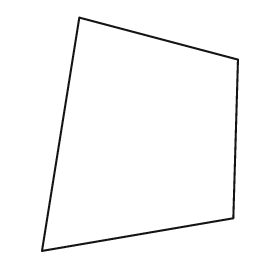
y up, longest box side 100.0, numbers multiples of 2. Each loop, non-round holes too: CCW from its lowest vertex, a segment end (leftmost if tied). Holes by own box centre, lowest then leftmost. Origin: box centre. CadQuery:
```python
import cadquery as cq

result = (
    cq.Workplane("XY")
    .moveTo(-42.0, -50.0)
    .lineTo(40.0, -36.0)
    .lineTo(42.0, 32.0)
    .lineTo(-26.0, 50.0)
    .close()
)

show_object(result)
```